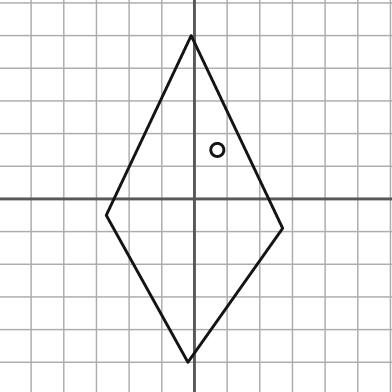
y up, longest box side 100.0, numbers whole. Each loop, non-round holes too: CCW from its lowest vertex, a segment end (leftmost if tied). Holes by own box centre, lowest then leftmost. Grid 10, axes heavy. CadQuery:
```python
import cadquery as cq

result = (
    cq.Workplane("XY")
    .moveTo(-2.0, -50.0)
    .lineTo(27.0, -9.0)
    .lineTo(-1.0, 50.0)
    .lineTo(-27.0, -5.0)
    .close()
    .moveTo(7.0, 15.0)
    .circle(2.0)
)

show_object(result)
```